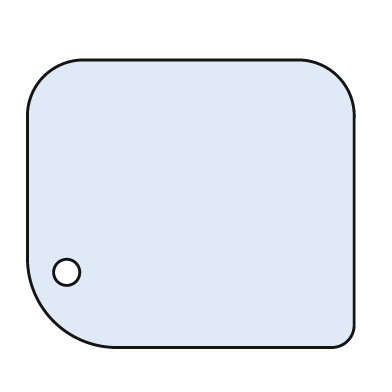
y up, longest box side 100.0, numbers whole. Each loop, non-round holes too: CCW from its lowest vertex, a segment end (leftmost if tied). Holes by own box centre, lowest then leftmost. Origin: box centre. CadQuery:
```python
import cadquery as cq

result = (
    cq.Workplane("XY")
    .moveTo(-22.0, -44.0)
    .lineTo(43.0, -44.0)
    .threePointArc((48.0, -42.0), (50.0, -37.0))
    .lineTo(50.0, 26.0)
    .threePointArc((45.0, 39.0), (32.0, 44.0))
    .lineTo(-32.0, 44.0)
    .threePointArc((-45.0, 39.0), (-50.0, 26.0))
    .lineTo(-50.0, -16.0)
    .threePointArc((-42.0, -36.0), (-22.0, -44.0))
    .close()
    .moveTo(-38.0, -21.0)
    .circle(4.0)
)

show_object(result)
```